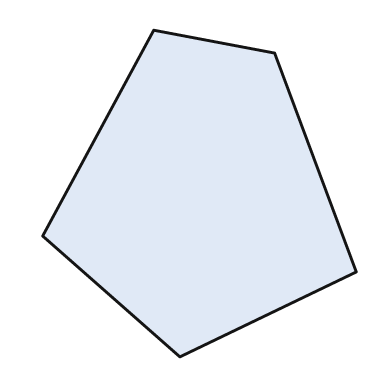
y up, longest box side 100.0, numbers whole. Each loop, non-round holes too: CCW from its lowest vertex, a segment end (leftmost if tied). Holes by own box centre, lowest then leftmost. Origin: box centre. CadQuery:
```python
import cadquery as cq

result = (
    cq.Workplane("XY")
    .moveTo(-6.0, -50.0)
    .lineTo(48.0, -24.0)
    .lineTo(23.0, 43.0)
    .lineTo(-14.0, 50.0)
    .lineTo(-48.0, -13.0)
    .close()
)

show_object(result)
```